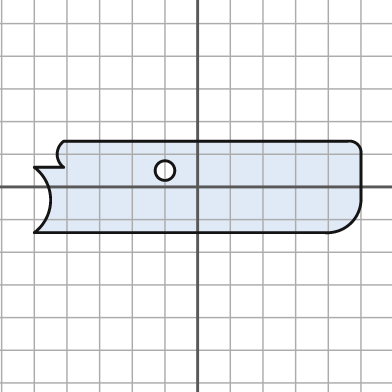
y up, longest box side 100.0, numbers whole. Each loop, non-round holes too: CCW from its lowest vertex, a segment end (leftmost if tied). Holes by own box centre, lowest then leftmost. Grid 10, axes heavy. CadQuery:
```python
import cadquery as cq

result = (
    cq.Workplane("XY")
    .moveTo(-50.0, -14.0)
    .lineTo(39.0, -14.0)
    .threePointArc((47.0, -11.0), (50.0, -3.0))
    .lineTo(50.0, 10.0)
    .threePointArc((49.0, 13.0), (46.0, 14.0))
    .lineTo(-41.0, 14.0)
    .threePointArc((-43.0, 10.0), (-41.0, 6.0))
    .lineTo(-50.0, 6.0)
    .threePointArc((-45.0, -4.0), (-50.0, -14.0))
    .close()
    .moveTo(-10.0, 5.0)
    .circle(3.0)
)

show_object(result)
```